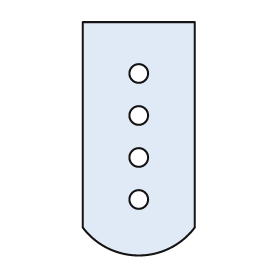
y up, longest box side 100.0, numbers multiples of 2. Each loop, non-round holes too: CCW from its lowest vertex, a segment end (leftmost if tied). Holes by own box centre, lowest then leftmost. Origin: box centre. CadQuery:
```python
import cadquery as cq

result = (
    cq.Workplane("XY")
    .moveTo(-24.0, -38.0)
    .threePointArc((0.0, -50.0), (24.0, -38.0))
    .lineTo(24.0, 50.0)
    .lineTo(-24.0, 50.0)
    .close()
    .moveTo(0.0, -26.0)
    .circle(4.0)
    .moveTo(0.0, -8.0)
    .circle(4.0)
    .moveTo(0.0, 10.0)
    .circle(4.0)
    .moveTo(0.0, 28.0)
    .circle(4.0)
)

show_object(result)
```